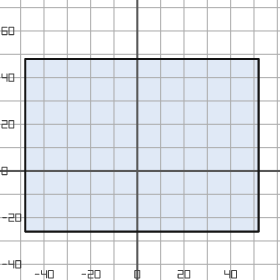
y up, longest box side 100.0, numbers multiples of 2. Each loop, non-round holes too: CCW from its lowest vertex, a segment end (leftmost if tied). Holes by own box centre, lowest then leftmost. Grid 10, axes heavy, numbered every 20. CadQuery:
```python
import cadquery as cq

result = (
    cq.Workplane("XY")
    .moveTo(-48.0, -26.0)
    .lineTo(52.0, -26.0)
    .lineTo(52.0, 48.0)
    .lineTo(-48.0, 48.0)
    .close()
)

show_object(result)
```